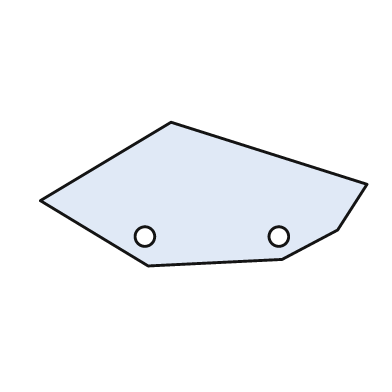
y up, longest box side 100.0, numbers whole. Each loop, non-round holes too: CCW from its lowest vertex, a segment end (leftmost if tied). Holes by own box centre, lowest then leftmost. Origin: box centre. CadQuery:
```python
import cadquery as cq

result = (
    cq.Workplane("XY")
    .moveTo(-17.0, -22.0)
    .lineTo(24.0, -20.0)
    .lineTo(41.0, -11.0)
    .lineTo(50.0, 3.0)
    .lineTo(-10.0, 22.0)
    .lineTo(-50.0, -2.0)
    .close()
    .moveTo(-18.0, -13.0)
    .circle(3.0)
    .moveTo(23.0, -13.0)
    .circle(3.0)
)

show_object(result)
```